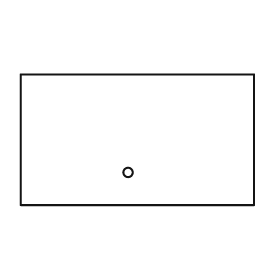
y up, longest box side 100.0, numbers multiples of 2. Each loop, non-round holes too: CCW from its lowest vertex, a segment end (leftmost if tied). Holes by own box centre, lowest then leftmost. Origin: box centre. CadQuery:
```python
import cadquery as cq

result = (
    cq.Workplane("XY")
    .moveTo(-50.0, -28.0)
    .lineTo(50.0, -28.0)
    .lineTo(50.0, 28.0)
    .lineTo(-50.0, 28.0)
    .close()
    .moveTo(-4.0, -14.0)
    .circle(2.0)
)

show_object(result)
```